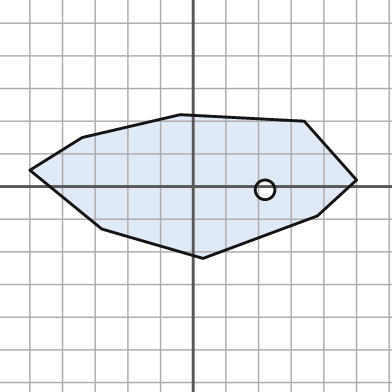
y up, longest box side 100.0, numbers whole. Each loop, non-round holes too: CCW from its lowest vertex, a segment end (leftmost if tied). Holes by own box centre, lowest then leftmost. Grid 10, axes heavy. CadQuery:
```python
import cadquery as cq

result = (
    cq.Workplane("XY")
    .moveTo(3.0, -22.0)
    .lineTo(38.0, -9.0)
    .lineTo(50.0, 2.0)
    .lineTo(34.0, 20.0)
    .lineTo(-4.0, 22.0)
    .lineTo(-34.0, 15.0)
    .lineTo(-50.0, 5.0)
    .lineTo(-28.0, -13.0)
    .close()
    .moveTo(22.0, -1.0)
    .circle(3.0)
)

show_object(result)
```